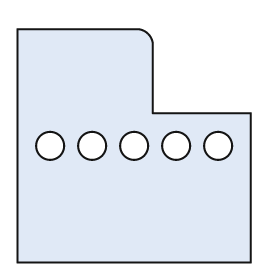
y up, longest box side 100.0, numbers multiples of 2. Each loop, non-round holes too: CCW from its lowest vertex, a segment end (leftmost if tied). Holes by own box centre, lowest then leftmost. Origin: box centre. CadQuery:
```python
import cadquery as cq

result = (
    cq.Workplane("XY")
    .moveTo(-50.0, -50.0)
    .lineTo(50.0, -50.0)
    .lineTo(50.0, 14.0)
    .lineTo(8.0, 14.0)
    .lineTo(8.0, 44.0)
    .threePointArc((6.0, 48.0), (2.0, 50.0))
    .lineTo(-50.0, 50.0)
    .close()
    .moveTo(-36.0, 0.0)
    .circle(6.0)
    .moveTo(-18.0, 0.0)
    .circle(6.0)
    .moveTo(0.0, 0.0)
    .circle(6.0)
    .moveTo(18.0, 0.0)
    .circle(6.0)
    .moveTo(36.0, 0.0)
    .circle(6.0)
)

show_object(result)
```